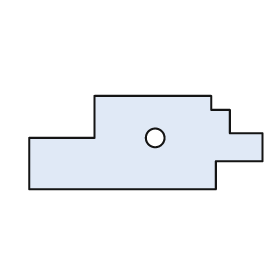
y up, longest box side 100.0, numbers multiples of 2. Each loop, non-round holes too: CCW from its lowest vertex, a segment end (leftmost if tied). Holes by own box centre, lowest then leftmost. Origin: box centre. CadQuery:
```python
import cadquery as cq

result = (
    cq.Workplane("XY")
    .moveTo(-50.0, -20.0)
    .lineTo(30.0, -20.0)
    .lineTo(30.0, -8.0)
    .lineTo(50.0, -8.0)
    .lineTo(50.0, 4.0)
    .lineTo(36.0, 4.0)
    .lineTo(36.0, 14.0)
    .lineTo(28.0, 14.0)
    .lineTo(28.0, 20.0)
    .lineTo(-22.0, 20.0)
    .lineTo(-22.0, 2.0)
    .lineTo(-50.0, 2.0)
    .close()
    .moveTo(4.0, 2.0)
    .circle(4.0)
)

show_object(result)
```